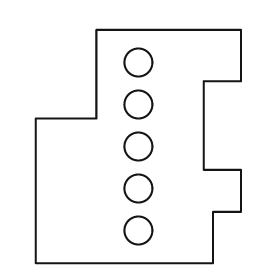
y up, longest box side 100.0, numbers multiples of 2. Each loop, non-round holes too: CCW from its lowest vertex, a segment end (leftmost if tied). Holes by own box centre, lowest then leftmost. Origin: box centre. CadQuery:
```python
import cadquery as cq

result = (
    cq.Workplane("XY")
    .moveTo(-44.0, -50.0)
    .lineTo(32.0, -50.0)
    .lineTo(32.0, -28.0)
    .lineTo(44.0, -28.0)
    .lineTo(44.0, -10.0)
    .lineTo(28.0, -10.0)
    .lineTo(28.0, 28.0)
    .lineTo(44.0, 28.0)
    .lineTo(44.0, 50.0)
    .lineTo(-18.0, 50.0)
    .lineTo(-18.0, 12.0)
    .lineTo(-44.0, 12.0)
    .close()
    .moveTo(0.0, -36.0)
    .circle(6.0)
    .moveTo(0.0, -18.0)
    .circle(6.0)
    .moveTo(0.0, 0.0)
    .circle(6.0)
    .moveTo(0.0, 18.0)
    .circle(6.0)
    .moveTo(0.0, 36.0)
    .circle(6.0)
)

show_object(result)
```